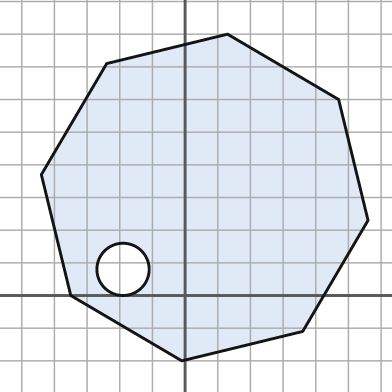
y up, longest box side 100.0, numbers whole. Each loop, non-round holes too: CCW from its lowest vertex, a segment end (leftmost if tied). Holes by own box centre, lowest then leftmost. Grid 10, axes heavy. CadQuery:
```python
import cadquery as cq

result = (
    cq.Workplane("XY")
    .moveTo(-1.0, -20.0)
    .lineTo(36.0, -11.0)
    .lineTo(56.0, 23.0)
    .lineTo(47.0, 60.0)
    .lineTo(13.0, 80.0)
    .lineTo(-24.0, 71.0)
    .lineTo(-44.0, 37.0)
    .lineTo(-35.0, 0.0)
    .close()
    .moveTo(-19.0, 8.0)
    .circle(8.0)
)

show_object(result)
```